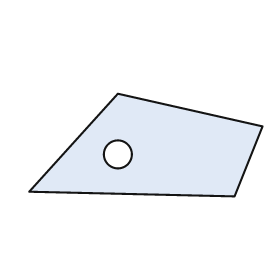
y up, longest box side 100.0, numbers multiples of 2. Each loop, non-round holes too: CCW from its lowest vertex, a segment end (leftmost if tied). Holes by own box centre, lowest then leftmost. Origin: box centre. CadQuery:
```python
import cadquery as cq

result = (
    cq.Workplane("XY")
    .moveTo(38.0, -22.0)
    .lineTo(50.0, 8.0)
    .lineTo(-12.0, 22.0)
    .lineTo(-50.0, -20.0)
    .close()
    .moveTo(-12.0, -4.0)
    .circle(6.0)
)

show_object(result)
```